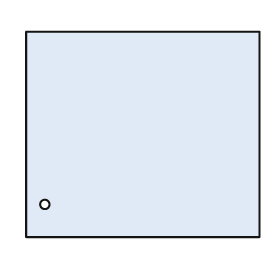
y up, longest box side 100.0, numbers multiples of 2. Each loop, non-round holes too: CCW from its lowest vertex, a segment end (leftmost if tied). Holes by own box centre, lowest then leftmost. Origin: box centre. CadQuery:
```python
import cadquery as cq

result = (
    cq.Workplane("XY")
    .moveTo(-50.0, -44.0)
    .lineTo(50.0, -44.0)
    .lineTo(50.0, 44.0)
    .lineTo(-50.0, 44.0)
    .close()
    .moveTo(-42.0, -30.0)
    .circle(2.0)
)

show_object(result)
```